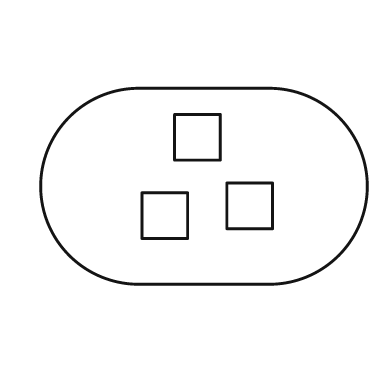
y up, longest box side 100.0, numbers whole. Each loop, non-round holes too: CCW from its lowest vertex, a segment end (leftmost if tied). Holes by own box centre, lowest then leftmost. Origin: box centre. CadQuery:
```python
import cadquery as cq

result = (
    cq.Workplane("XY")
    .moveTo(-20.0, -30.0)
    .lineTo(20.0, -30.0)
    .threePointArc((50.0, 0.0), (20.0, 30.0))
    .lineTo(-20.0, 30.0)
    .threePointArc((-50.0, 0.0), (-20.0, -30.0))
    .close()
    .moveTo(-19.0, -16.0)
    .lineTo(-5.0, -16.0)
    .lineTo(-5.0, -2.0)
    .lineTo(-19.0, -2.0)
    .close()
    .moveTo(7.0, -13.0)
    .lineTo(21.0, -13.0)
    .lineTo(21.0, 1.0)
    .lineTo(7.0, 1.0)
    .close()
    .moveTo(-9.0, 8.0)
    .lineTo(5.0, 8.0)
    .lineTo(5.0, 22.0)
    .lineTo(-9.0, 22.0)
    .close()
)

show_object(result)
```